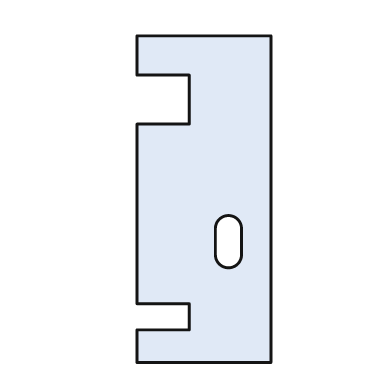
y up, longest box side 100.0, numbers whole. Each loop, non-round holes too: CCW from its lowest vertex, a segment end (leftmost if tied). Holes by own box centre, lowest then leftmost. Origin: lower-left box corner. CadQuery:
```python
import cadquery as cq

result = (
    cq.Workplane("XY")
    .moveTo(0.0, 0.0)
    .lineTo(41.0, 0.0)
    .lineTo(41.0, 100.0)
    .lineTo(0.0, 100.0)
    .lineTo(0.0, 88.0)
    .lineTo(16.0, 88.0)
    .lineTo(16.0, 73.0)
    .lineTo(0.0, 73.0)
    .lineTo(0.0, 18.0)
    .lineTo(16.0, 18.0)
    .lineTo(16.0, 10.0)
    .lineTo(0.0, 10.0)
    .close()
    .moveTo(24.0, 33.0)
    .threePointArc((28.0, 29.0), (32.0, 33.0))
    .lineTo(32.0, 41.0)
    .threePointArc((28.0, 45.0), (24.0, 41.0))
    .close()
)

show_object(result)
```